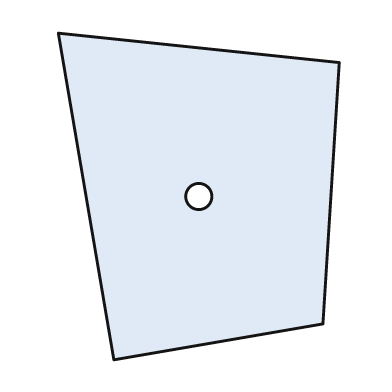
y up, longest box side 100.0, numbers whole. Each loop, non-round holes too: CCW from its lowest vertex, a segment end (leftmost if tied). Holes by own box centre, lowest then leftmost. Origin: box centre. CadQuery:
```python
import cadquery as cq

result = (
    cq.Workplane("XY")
    .moveTo(-26.0, -50.0)
    .lineTo(38.0, -39.0)
    .lineTo(43.0, 41.0)
    .lineTo(-43.0, 50.0)
    .close()
    .moveTo(0.0, 0.0)
    .circle(4.0)
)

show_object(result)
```